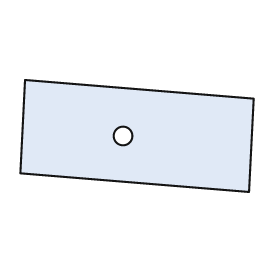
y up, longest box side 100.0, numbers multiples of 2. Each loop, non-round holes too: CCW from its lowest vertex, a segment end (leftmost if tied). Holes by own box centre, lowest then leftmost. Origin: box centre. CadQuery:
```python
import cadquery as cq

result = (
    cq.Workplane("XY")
    .moveTo(48.0, -24.0)
    .lineTo(50.0, 16.0)
    .lineTo(-48.0, 24.0)
    .lineTo(-50.0, -16.0)
    .close()
    .moveTo(-6.0, 0.0)
    .circle(4.0)
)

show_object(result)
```